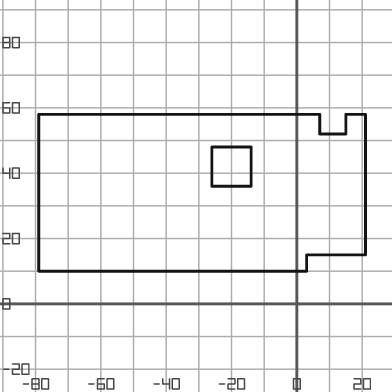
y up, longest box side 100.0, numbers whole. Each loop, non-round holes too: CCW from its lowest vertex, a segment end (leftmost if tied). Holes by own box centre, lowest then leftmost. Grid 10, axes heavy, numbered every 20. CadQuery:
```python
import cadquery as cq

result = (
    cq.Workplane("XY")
    .moveTo(-79.0, 10.0)
    .lineTo(3.0, 10.0)
    .lineTo(3.0, 15.0)
    .lineTo(21.0, 15.0)
    .lineTo(21.0, 58.0)
    .lineTo(15.0, 58.0)
    .lineTo(15.0, 52.0)
    .lineTo(7.0, 52.0)
    .lineTo(7.0, 58.0)
    .lineTo(-79.0, 58.0)
    .close()
    .moveTo(-26.0, 36.0)
    .lineTo(-14.0, 36.0)
    .lineTo(-14.0, 48.0)
    .lineTo(-26.0, 48.0)
    .close()
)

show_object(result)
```